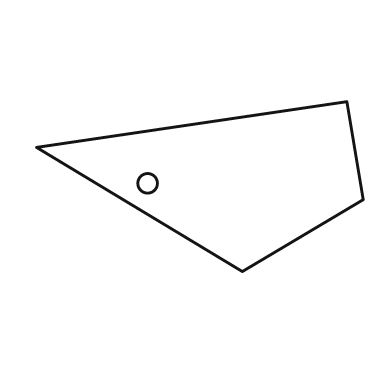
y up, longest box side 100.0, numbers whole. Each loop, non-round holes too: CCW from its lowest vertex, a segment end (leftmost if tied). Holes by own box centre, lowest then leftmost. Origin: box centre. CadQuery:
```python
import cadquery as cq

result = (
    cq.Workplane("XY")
    .moveTo(13.0, -26.0)
    .lineTo(50.0, -4.0)
    .lineTo(45.0, 26.0)
    .lineTo(-50.0, 12.0)
    .close()
    .moveTo(-16.0, 1.0)
    .circle(3.0)
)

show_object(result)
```